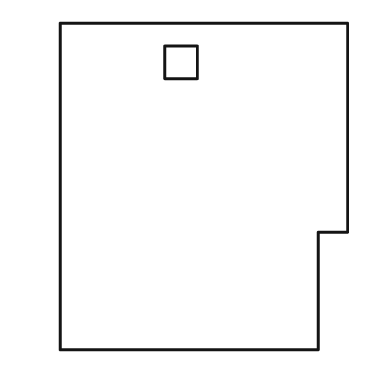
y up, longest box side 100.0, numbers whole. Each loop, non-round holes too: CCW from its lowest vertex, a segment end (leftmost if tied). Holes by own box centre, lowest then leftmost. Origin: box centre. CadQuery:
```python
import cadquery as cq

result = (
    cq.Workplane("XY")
    .moveTo(-44.0, -50.0)
    .lineTo(35.0, -50.0)
    .lineTo(35.0, -14.0)
    .lineTo(44.0, -14.0)
    .lineTo(44.0, 50.0)
    .lineTo(-44.0, 50.0)
    .close()
    .moveTo(-12.0, 33.0)
    .lineTo(-2.0, 33.0)
    .lineTo(-2.0, 43.0)
    .lineTo(-12.0, 43.0)
    .close()
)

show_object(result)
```